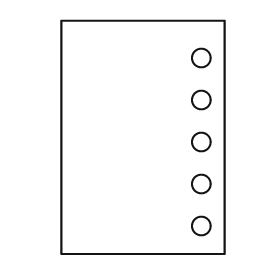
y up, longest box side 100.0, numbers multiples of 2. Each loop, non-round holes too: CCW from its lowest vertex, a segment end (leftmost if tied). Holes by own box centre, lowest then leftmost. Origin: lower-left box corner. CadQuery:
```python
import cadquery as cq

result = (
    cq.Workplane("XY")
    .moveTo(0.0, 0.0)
    .lineTo(70.0, 0.0)
    .lineTo(70.0, 100.0)
    .lineTo(0.0, 100.0)
    .close()
    .moveTo(60.0, 12.0)
    .circle(4.0)
    .moveTo(60.0, 30.0)
    .circle(4.0)
    .moveTo(60.0, 48.0)
    .circle(4.0)
    .moveTo(60.0, 66.0)
    .circle(4.0)
    .moveTo(60.0, 84.0)
    .circle(4.0)
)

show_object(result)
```